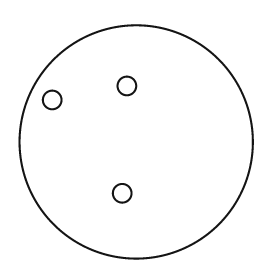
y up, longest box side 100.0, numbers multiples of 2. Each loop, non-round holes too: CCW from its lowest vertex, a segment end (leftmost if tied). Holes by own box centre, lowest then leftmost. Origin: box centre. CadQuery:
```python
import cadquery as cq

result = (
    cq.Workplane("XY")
    .moveTo(0.0, 0.0)
    .circle(50.0)
    .moveTo(-6.0, -22.0)
    .circle(4.0)
    .moveTo(-36.0, 18.0)
    .circle(4.0)
    .moveTo(-4.0, 24.0)
    .circle(4.0)
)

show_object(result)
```